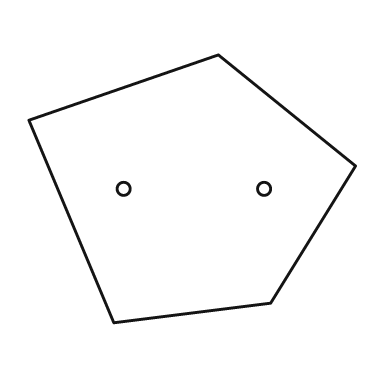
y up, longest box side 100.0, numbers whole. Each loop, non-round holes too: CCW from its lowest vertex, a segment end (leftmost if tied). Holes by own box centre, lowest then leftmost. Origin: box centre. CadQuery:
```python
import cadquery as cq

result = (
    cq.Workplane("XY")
    .moveTo(-24.0, -41.0)
    .lineTo(24.0, -35.0)
    .lineTo(50.0, 7.0)
    .lineTo(8.0, 41.0)
    .lineTo(-50.0, 21.0)
    .close()
    .moveTo(-21.0, 0.0)
    .circle(2.0)
    .moveTo(22.0, 0.0)
    .circle(2.0)
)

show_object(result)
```